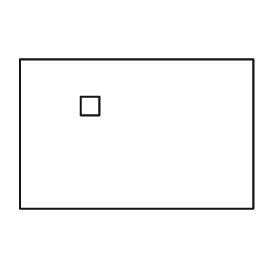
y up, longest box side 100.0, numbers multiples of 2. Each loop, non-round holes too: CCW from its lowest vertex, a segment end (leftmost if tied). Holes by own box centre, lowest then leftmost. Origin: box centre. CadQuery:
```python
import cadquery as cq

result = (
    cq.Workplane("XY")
    .moveTo(-50.0, -32.0)
    .lineTo(50.0, -32.0)
    .lineTo(50.0, 32.0)
    .lineTo(-50.0, 32.0)
    .close()
    .moveTo(-24.0, 8.0)
    .lineTo(-16.0, 8.0)
    .lineTo(-16.0, 16.0)
    .lineTo(-24.0, 16.0)
    .close()
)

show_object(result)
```